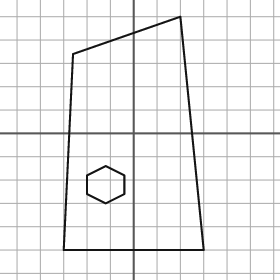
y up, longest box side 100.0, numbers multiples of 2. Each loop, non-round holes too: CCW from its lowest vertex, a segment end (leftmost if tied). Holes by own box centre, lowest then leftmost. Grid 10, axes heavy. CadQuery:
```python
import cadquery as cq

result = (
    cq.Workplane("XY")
    .moveTo(-30.0, -50.0)
    .lineTo(30.0, -50.0)
    .lineTo(20.0, 50.0)
    .lineTo(-26.0, 34.0)
    .close()
    .moveTo(-12.0, -30.0)
    .lineTo(-4.0, -26.0)
    .lineTo(-4.0, -18.0)
    .lineTo(-12.0, -14.0)
    .lineTo(-20.0, -18.0)
    .lineTo(-20.0, -26.0)
    .close()
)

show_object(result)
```